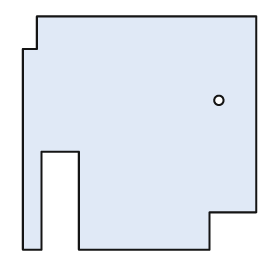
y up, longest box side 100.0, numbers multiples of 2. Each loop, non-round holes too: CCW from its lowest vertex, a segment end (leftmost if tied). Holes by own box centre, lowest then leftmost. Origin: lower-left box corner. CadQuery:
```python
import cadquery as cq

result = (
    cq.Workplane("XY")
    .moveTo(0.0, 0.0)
    .lineTo(8.0, 0.0)
    .lineTo(8.0, 42.0)
    .lineTo(24.0, 42.0)
    .lineTo(24.0, 0.0)
    .lineTo(80.0, 0.0)
    .lineTo(80.0, 16.0)
    .lineTo(100.0, 16.0)
    .lineTo(100.0, 100.0)
    .lineTo(6.0, 100.0)
    .lineTo(6.0, 86.0)
    .lineTo(0.0, 86.0)
    .close()
    .moveTo(84.0, 64.0)
    .circle(2.0)
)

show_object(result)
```